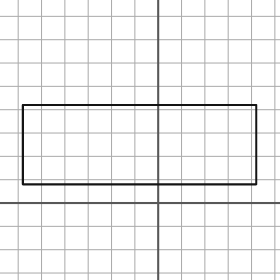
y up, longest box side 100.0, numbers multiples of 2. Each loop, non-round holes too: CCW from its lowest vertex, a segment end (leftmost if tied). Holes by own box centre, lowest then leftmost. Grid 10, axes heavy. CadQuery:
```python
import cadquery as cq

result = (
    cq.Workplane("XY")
    .moveTo(-58.0, 8.0)
    .lineTo(42.0, 8.0)
    .lineTo(42.0, 42.0)
    .lineTo(-58.0, 42.0)
    .close()
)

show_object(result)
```